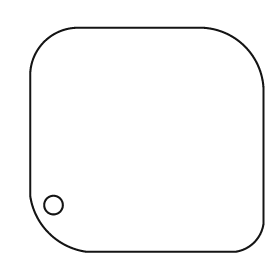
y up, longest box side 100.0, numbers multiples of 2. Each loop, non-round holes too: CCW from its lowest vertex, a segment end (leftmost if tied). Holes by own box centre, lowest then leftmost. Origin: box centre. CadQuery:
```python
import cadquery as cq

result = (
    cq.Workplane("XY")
    .moveTo(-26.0, -48.0)
    .lineTo(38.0, -48.0)
    .threePointArc((46.0, -44.0), (50.0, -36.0))
    .lineTo(50.0, 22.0)
    .threePointArc((42.0, 40.0), (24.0, 48.0))
    .lineTo(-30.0, 48.0)
    .threePointArc((-44.0, 42.0), (-50.0, 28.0))
    .lineTo(-50.0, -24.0)
    .threePointArc((-42.0, -40.0), (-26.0, -48.0))
    .close()
    .moveTo(-40.0, -28.0)
    .circle(4.0)
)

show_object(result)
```